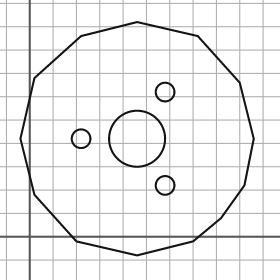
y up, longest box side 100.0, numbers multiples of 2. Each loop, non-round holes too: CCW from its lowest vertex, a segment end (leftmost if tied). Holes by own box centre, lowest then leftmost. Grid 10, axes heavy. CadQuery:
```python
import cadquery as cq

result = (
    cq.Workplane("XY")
    .moveTo(46.0, -8.0)
    .lineTo(70.0, -2.0)
    .lineTo(82.0, 8.0)
    .lineTo(92.0, 22.0)
    .lineTo(96.0, 42.0)
    .lineTo(90.0, 66.0)
    .lineTo(72.0, 86.0)
    .lineTo(46.0, 92.0)
    .lineTo(22.0, 86.0)
    .lineTo(2.0, 68.0)
    .lineTo(-4.0, 42.0)
    .lineTo(2.0, 18.0)
    .lineTo(20.0, -2.0)
    .close()
    .moveTo(58.0, 22.0)
    .circle(4.0)
    .moveTo(22.0, 42.0)
    .circle(4.0)
    .moveTo(46.0, 42.0)
    .circle(12.0)
    .moveTo(58.0, 62.0)
    .circle(4.0)
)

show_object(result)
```